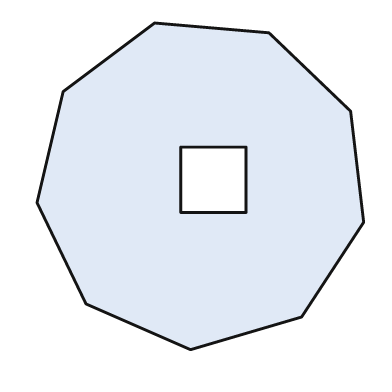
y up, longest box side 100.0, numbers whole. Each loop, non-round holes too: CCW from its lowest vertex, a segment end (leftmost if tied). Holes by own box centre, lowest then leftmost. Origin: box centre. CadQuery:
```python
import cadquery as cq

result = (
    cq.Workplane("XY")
    .moveTo(-3.0, -50.0)
    .lineTo(31.0, -40.0)
    .lineTo(50.0, -11.0)
    .lineTo(46.0, 23.0)
    .lineTo(21.0, 47.0)
    .lineTo(-14.0, 50.0)
    .lineTo(-42.0, 29.0)
    .lineTo(-50.0, -5.0)
    .lineTo(-35.0, -36.0)
    .close()
    .moveTo(-6.0, -8.0)
    .lineTo(14.0, -8.0)
    .lineTo(14.0, 12.0)
    .lineTo(-6.0, 12.0)
    .close()
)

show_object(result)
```